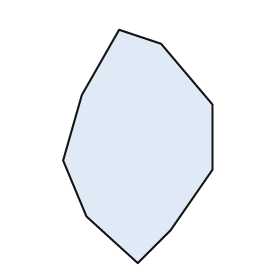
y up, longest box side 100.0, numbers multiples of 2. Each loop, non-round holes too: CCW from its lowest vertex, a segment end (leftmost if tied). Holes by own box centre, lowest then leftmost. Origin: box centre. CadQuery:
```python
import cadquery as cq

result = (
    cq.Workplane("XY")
    .moveTo(0.0, -50.0)
    .lineTo(14.0, -36.0)
    .lineTo(32.0, -10.0)
    .lineTo(32.0, 18.0)
    .lineTo(10.0, 44.0)
    .lineTo(-8.0, 50.0)
    .lineTo(-24.0, 22.0)
    .lineTo(-32.0, -6.0)
    .lineTo(-22.0, -30.0)
    .close()
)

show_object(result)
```